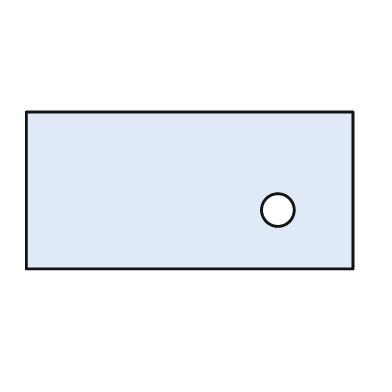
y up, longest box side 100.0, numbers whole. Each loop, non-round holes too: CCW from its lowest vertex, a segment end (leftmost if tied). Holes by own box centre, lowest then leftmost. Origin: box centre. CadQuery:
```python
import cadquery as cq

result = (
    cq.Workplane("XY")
    .moveTo(-50.0, -24.0)
    .lineTo(50.0, -24.0)
    .lineTo(50.0, 24.0)
    .lineTo(-50.0, 24.0)
    .close()
    .moveTo(27.0, -6.0)
    .circle(5.0)
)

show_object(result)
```